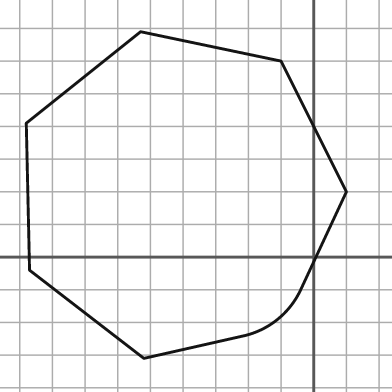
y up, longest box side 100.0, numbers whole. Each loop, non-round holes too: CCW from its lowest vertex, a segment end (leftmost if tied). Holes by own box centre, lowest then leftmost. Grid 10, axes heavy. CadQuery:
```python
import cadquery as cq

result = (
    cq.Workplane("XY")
    .moveTo(-52.0, -31.0)
    .lineTo(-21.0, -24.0)
    .threePointArc((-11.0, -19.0), (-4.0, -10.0))
    .lineTo(10.0, 20.0)
    .lineTo(-10.0, 60.0)
    .lineTo(-53.0, 69.0)
    .lineTo(-88.0, 41.0)
    .lineTo(-87.0, -4.0)
    .close()
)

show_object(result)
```